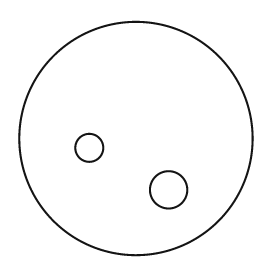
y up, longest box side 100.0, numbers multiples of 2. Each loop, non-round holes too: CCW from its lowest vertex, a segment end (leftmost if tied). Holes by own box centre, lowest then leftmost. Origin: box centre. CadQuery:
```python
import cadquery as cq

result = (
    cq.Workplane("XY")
    .moveTo(0.0, 0.0)
    .circle(50.0)
    .moveTo(14.0, -22.0)
    .circle(8.0)
    .moveTo(-20.0, -4.0)
    .circle(6.0)
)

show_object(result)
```